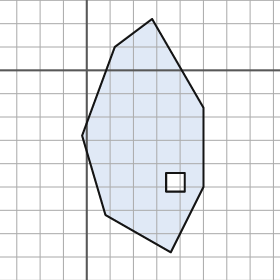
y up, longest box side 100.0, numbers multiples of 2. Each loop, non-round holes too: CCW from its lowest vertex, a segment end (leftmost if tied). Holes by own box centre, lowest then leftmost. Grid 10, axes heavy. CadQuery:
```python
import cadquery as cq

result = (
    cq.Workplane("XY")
    .moveTo(36.0, -78.0)
    .lineTo(50.0, -50.0)
    .lineTo(50.0, -16.0)
    .lineTo(28.0, 22.0)
    .lineTo(12.0, 10.0)
    .lineTo(-2.0, -28.0)
    .lineTo(8.0, -62.0)
    .close()
    .moveTo(34.0, -52.0)
    .lineTo(42.0, -52.0)
    .lineTo(42.0, -44.0)
    .lineTo(34.0, -44.0)
    .close()
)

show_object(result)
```